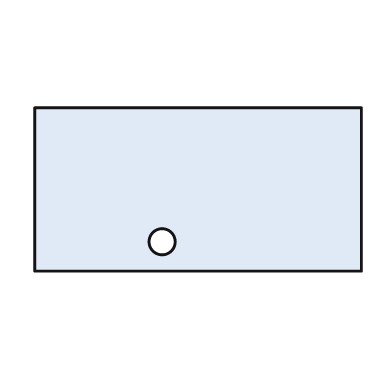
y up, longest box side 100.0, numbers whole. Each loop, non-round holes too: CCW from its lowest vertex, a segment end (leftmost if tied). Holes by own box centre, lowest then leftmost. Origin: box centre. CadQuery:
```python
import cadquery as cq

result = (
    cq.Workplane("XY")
    .moveTo(-50.0, -25.0)
    .lineTo(50.0, -25.0)
    .lineTo(50.0, 25.0)
    .lineTo(-50.0, 25.0)
    .close()
    .moveTo(-11.0, -16.0)
    .circle(4.0)
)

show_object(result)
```